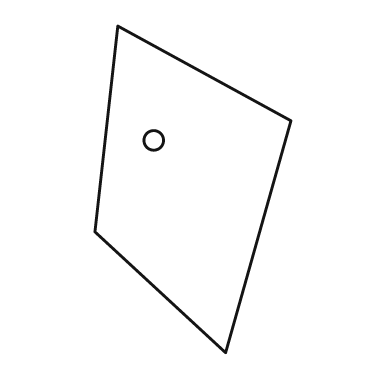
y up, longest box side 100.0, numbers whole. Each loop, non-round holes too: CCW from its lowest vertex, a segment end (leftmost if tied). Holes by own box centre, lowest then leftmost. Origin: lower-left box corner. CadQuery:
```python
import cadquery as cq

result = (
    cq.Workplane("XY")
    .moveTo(40.0, 0.0)
    .lineTo(60.0, 71.0)
    .lineTo(7.0, 100.0)
    .lineTo(0.0, 37.0)
    .close()
    .moveTo(18.0, 65.0)
    .circle(3.0)
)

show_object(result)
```